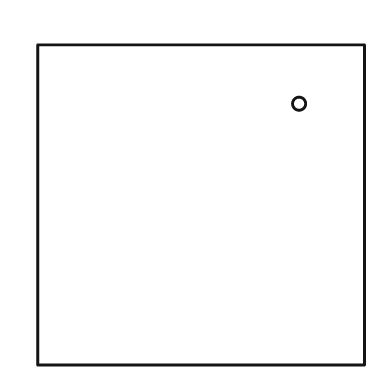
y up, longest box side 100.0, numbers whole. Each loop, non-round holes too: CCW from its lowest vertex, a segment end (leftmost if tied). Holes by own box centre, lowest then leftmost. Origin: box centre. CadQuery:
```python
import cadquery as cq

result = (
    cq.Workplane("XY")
    .moveTo(-50.0, -49.0)
    .lineTo(50.0, -49.0)
    .lineTo(50.0, 49.0)
    .lineTo(-50.0, 49.0)
    .close()
    .moveTo(30.0, 31.0)
    .circle(2.0)
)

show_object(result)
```